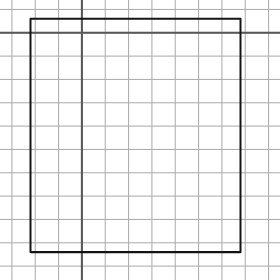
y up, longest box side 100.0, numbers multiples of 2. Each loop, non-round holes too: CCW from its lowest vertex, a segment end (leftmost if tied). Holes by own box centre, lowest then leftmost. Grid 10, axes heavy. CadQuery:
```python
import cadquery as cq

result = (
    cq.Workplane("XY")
    .moveTo(-22.0, -94.0)
    .lineTo(68.0, -94.0)
    .lineTo(68.0, 6.0)
    .lineTo(-22.0, 6.0)
    .close()
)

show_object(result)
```